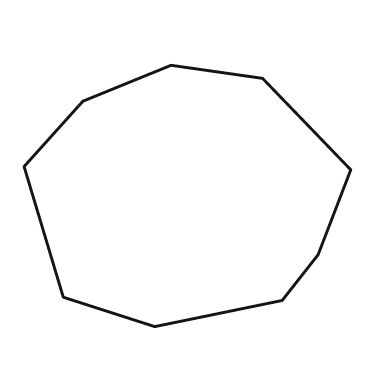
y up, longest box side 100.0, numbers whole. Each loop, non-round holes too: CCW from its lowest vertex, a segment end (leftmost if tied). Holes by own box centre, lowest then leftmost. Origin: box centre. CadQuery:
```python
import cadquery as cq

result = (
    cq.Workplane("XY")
    .moveTo(-10.0, -40.0)
    .lineTo(29.0, -32.0)
    .lineTo(40.0, -18.0)
    .lineTo(50.0, 8.0)
    .lineTo(23.0, 36.0)
    .lineTo(-5.0, 40.0)
    .lineTo(-32.0, 29.0)
    .lineTo(-50.0, 9.0)
    .lineTo(-38.0, -31.0)
    .close()
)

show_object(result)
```